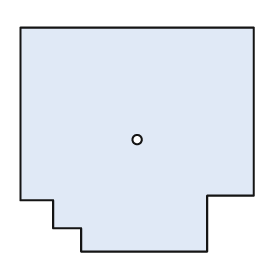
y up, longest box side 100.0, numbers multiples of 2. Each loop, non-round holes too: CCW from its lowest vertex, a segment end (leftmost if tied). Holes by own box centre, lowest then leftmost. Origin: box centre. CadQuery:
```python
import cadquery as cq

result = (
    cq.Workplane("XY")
    .moveTo(-24.0, -48.0)
    .lineTo(30.0, -48.0)
    .lineTo(30.0, -24.0)
    .lineTo(50.0, -24.0)
    .lineTo(50.0, 48.0)
    .lineTo(-50.0, 48.0)
    .lineTo(-50.0, -26.0)
    .lineTo(-36.0, -26.0)
    .lineTo(-36.0, -38.0)
    .lineTo(-24.0, -38.0)
    .close()
    .moveTo(0.0, 0.0)
    .circle(2.0)
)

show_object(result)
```